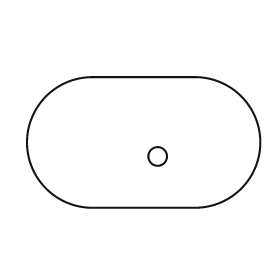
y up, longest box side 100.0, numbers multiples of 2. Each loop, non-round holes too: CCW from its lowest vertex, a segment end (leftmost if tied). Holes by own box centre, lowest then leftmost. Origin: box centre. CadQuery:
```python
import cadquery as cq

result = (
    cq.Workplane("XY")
    .moveTo(-22.0, -28.0)
    .lineTo(22.0, -28.0)
    .threePointArc((50.0, 0.0), (22.0, 28.0))
    .lineTo(-22.0, 28.0)
    .threePointArc((-50.0, 0.0), (-22.0, -28.0))
    .close()
    .moveTo(6.0, -6.0)
    .circle(4.0)
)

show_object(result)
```